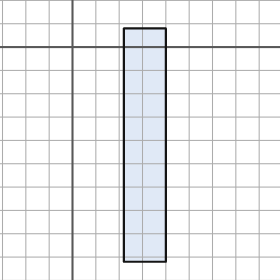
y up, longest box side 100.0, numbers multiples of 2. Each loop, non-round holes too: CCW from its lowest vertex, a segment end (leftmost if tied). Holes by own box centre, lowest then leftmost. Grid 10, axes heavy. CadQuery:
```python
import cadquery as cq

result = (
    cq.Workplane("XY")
    .moveTo(22.0, -92.0)
    .lineTo(40.0, -92.0)
    .lineTo(40.0, 8.0)
    .lineTo(22.0, 8.0)
    .close()
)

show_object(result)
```